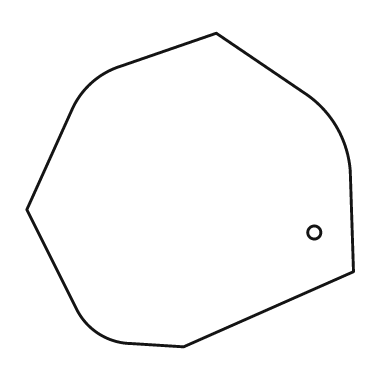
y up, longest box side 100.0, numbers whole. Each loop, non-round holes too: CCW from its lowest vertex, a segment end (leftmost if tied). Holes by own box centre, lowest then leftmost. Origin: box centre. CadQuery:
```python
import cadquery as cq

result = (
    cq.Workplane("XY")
    .moveTo(-2.0, -48.0)
    .lineTo(50.0, -25.0)
    .lineTo(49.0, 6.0)
    .threePointArc((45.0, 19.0), (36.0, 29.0))
    .lineTo(8.0, 48.0)
    .lineTo(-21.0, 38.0)
    .threePointArc((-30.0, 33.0), (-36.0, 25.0))
    .lineTo(-50.0, -6.0)
    .lineTo(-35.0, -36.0)
    .threePointArc((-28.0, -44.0), (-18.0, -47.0))
    .close()
    .moveTo(38.0, -13.0)
    .circle(2.0)
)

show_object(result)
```